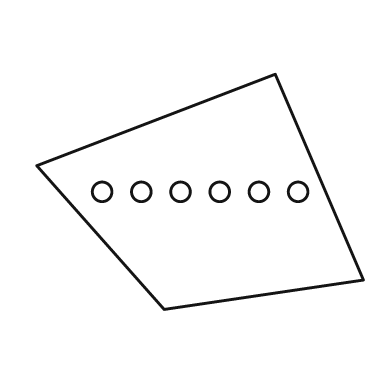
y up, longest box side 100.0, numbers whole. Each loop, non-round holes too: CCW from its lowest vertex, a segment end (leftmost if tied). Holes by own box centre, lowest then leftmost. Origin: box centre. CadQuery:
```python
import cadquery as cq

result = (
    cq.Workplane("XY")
    .moveTo(-11.0, -36.0)
    .lineTo(50.0, -27.0)
    .lineTo(23.0, 36.0)
    .lineTo(-50.0, 8.0)
    .close()
    .moveTo(-30.0, 0.0)
    .circle(3.0)
    .moveTo(-18.0, 0.0)
    .circle(3.0)
    .moveTo(-6.0, 0.0)
    .circle(3.0)
    .moveTo(6.0, 0.0)
    .circle(3.0)
    .moveTo(18.0, 0.0)
    .circle(3.0)
    .moveTo(30.0, 0.0)
    .circle(3.0)
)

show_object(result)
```